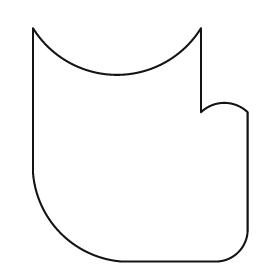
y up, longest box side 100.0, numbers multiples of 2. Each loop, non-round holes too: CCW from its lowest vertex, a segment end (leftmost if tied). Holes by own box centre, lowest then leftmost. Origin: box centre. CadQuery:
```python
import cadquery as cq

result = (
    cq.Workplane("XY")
    .moveTo(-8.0, -50.0)
    .lineTo(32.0, -50.0)
    .threePointArc((42.0, -46.0), (46.0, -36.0))
    .lineTo(46.0, 14.0)
    .threePointArc((36.0, 18.0), (26.0, 14.0))
    .lineTo(26.0, 50.0)
    .threePointArc((-10.0, 30.0), (-46.0, 50.0))
    .lineTo(-46.0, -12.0)
    .threePointArc((-34.0, -38.0), (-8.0, -50.0))
    .close()
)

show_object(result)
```